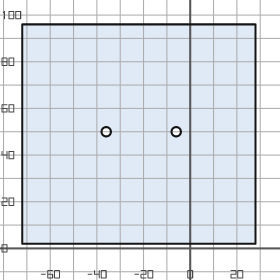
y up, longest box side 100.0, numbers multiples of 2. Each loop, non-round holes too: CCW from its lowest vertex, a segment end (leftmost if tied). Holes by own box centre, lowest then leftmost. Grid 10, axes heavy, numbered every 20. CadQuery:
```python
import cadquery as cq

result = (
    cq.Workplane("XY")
    .moveTo(-72.0, 2.0)
    .lineTo(28.0, 2.0)
    .lineTo(28.0, 96.0)
    .lineTo(-72.0, 96.0)
    .close()
    .moveTo(-36.0, 50.0)
    .circle(2.0)
    .moveTo(-6.0, 50.0)
    .circle(2.0)
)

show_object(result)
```